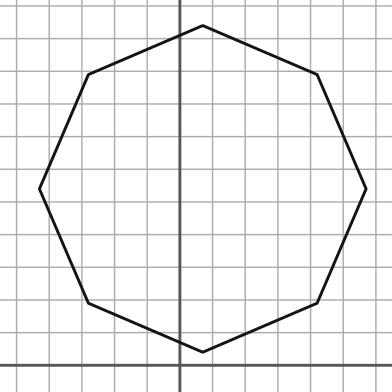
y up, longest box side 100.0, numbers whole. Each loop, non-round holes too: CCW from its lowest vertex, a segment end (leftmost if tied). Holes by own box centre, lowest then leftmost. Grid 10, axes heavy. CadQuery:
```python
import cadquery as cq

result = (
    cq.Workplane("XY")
    .moveTo(7.0, 4.0)
    .lineTo(42.0, 19.0)
    .lineTo(57.0, 54.0)
    .lineTo(42.0, 89.0)
    .lineTo(7.0, 104.0)
    .lineTo(-28.0, 89.0)
    .lineTo(-43.0, 54.0)
    .lineTo(-28.0, 19.0)
    .close()
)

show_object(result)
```